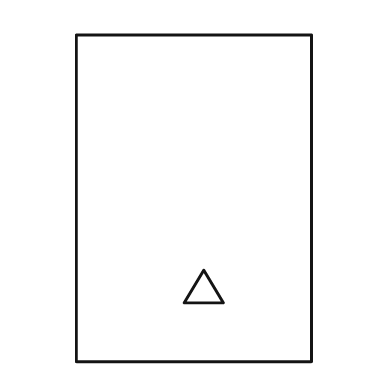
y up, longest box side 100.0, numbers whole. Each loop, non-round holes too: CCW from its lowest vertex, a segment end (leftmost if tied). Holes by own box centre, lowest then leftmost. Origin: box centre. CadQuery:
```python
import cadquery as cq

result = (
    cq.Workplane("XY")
    .moveTo(-36.0, -50.0)
    .lineTo(36.0, -50.0)
    .lineTo(36.0, 50.0)
    .lineTo(-36.0, 50.0)
    .close()
    .moveTo(-3.0, -32.0)
    .lineTo(9.0, -32.0)
    .lineTo(3.0, -22.0)
    .close()
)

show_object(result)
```